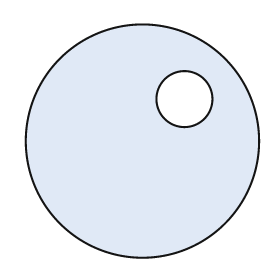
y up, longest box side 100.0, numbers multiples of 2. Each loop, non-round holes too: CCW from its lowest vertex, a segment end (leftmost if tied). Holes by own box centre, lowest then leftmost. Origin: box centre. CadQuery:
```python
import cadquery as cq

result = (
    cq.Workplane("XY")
    .moveTo(0.0, 0.0)
    .circle(50.0)
    .moveTo(18.0, 18.0)
    .circle(12.0)
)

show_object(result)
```